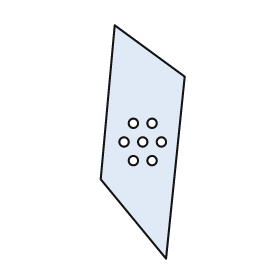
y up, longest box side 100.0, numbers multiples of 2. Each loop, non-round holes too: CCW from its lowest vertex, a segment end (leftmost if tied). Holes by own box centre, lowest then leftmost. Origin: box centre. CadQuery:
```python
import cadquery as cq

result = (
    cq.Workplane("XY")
    .moveTo(10.0, -50.0)
    .lineTo(18.0, 28.0)
    .lineTo(-12.0, 50.0)
    .lineTo(-18.0, -16.0)
    .close()
    .moveTo(-4.0, -8.0)
    .circle(2.0)
    .moveTo(4.0, -8.0)
    .circle(2.0)
    .moveTo(-8.0, 0.0)
    .circle(2.0)
    .moveTo(0.0, 0.0)
    .circle(2.0)
    .moveTo(8.0, 0.0)
    .circle(2.0)
    .moveTo(-4.0, 8.0)
    .circle(2.0)
    .moveTo(4.0, 8.0)
    .circle(2.0)
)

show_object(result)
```